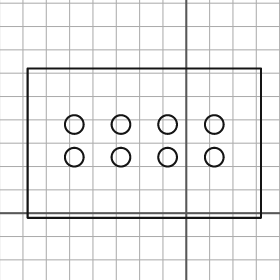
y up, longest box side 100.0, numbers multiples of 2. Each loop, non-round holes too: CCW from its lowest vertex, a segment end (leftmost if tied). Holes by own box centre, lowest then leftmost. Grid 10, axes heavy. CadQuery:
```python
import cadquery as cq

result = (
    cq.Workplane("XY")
    .moveTo(-68.0, -2.0)
    .lineTo(32.0, -2.0)
    .lineTo(32.0, 62.0)
    .lineTo(-68.0, 62.0)
    .close()
    .moveTo(-48.0, 24.0)
    .circle(4.0)
    .moveTo(-28.0, 24.0)
    .circle(4.0)
    .moveTo(-8.0, 24.0)
    .circle(4.0)
    .moveTo(12.0, 24.0)
    .circle(4.0)
    .moveTo(-48.0, 38.0)
    .circle(4.0)
    .moveTo(-28.0, 38.0)
    .circle(4.0)
    .moveTo(-8.0, 38.0)
    .circle(4.0)
    .moveTo(12.0, 38.0)
    .circle(4.0)
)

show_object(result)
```